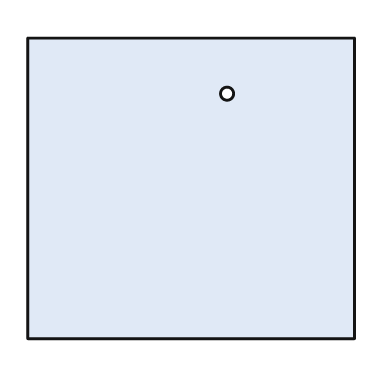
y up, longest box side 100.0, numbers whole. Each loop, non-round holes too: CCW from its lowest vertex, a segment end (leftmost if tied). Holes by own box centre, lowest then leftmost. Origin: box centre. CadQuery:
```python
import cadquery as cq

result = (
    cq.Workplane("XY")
    .moveTo(-50.0, -46.0)
    .lineTo(50.0, -46.0)
    .lineTo(50.0, 46.0)
    .lineTo(-50.0, 46.0)
    .close()
    .moveTo(11.0, 29.0)
    .circle(2.0)
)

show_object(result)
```